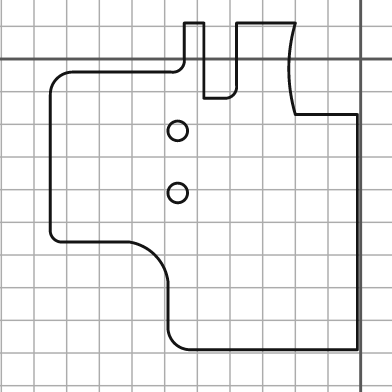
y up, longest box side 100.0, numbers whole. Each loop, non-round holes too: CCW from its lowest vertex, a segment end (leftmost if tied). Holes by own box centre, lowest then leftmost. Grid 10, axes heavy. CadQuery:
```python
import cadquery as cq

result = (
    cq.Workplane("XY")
    .moveTo(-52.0, -89.0)
    .lineTo(-1.0, -89.0)
    .lineTo(-1.0, -17.0)
    .lineTo(-20.0, -17.0)
    .threePointArc((-22.0, -3.0), (-20.0, 11.0))
    .lineTo(-38.0, 11.0)
    .lineTo(-38.0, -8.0)
    .threePointArc((-39.0, -11.0), (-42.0, -12.0))
    .lineTo(-48.0, -12.0)
    .lineTo(-48.0, 11.0)
    .lineTo(-54.0, 11.0)
    .lineTo(-54.0, 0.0)
    .threePointArc((-55.0, -3.0), (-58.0, -4.0))
    .lineTo(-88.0, -4.0)
    .threePointArc((-93.0, -6.0), (-95.0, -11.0))
    .lineTo(-95.0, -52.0)
    .threePointArc((-94.0, -55.0), (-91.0, -56.0))
    .lineTo(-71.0, -56.0)
    .threePointArc((-63.0, -60.0), (-59.0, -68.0))
    .lineTo(-59.0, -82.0)
    .threePointArc((-57.0, -87.0), (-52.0, -89.0))
    .close()
    .moveTo(-56.0, -41.0)
    .circle(3.0)
    .moveTo(-56.0, -22.0)
    .circle(3.0)
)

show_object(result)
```